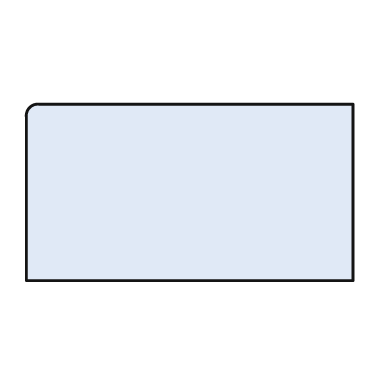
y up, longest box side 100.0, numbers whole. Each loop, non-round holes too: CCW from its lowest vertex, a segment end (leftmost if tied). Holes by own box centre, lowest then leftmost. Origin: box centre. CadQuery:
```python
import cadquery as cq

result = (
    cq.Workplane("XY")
    .moveTo(-50.0, -27.0)
    .lineTo(50.0, -27.0)
    .lineTo(50.0, 27.0)
    .lineTo(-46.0, 27.0)
    .threePointArc((-49.0, 26.0), (-50.0, 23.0))
    .close()
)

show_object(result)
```